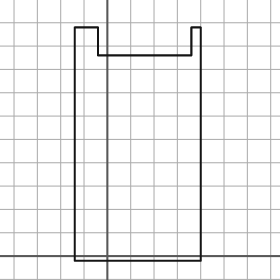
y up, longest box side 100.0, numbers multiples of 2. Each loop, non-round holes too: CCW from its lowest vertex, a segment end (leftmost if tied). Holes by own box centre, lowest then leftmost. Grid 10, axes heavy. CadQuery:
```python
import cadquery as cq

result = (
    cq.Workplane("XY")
    .moveTo(-14.0, -2.0)
    .lineTo(40.0, -2.0)
    .lineTo(40.0, 98.0)
    .lineTo(36.0, 98.0)
    .lineTo(36.0, 86.0)
    .lineTo(-4.0, 86.0)
    .lineTo(-4.0, 98.0)
    .lineTo(-14.0, 98.0)
    .close()
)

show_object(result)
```